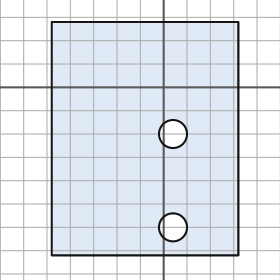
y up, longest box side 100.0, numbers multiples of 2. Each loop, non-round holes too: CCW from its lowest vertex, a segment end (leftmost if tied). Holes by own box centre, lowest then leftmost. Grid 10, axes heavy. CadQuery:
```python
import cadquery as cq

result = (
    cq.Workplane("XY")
    .moveTo(-48.0, -72.0)
    .lineTo(32.0, -72.0)
    .lineTo(32.0, 28.0)
    .lineTo(-48.0, 28.0)
    .close()
    .moveTo(4.0, -60.0)
    .circle(6.0)
    .moveTo(4.0, -20.0)
    .circle(6.0)
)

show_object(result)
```